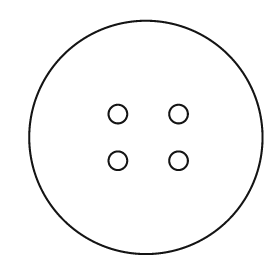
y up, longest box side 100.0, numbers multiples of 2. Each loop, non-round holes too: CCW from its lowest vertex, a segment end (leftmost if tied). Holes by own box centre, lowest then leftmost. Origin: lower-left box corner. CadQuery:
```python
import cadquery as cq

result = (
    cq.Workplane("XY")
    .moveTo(50.0, 50.0)
    .circle(50.0)
    .moveTo(38.0, 40.0)
    .circle(4.0)
    .moveTo(64.0, 40.0)
    .circle(4.0)
    .moveTo(38.0, 60.0)
    .circle(4.0)
    .moveTo(64.0, 60.0)
    .circle(4.0)
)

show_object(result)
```